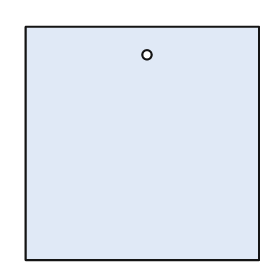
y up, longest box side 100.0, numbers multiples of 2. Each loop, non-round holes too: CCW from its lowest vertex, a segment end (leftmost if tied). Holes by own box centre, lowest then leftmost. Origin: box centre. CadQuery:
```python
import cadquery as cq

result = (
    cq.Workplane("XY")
    .moveTo(-50.0, -50.0)
    .lineTo(50.0, -50.0)
    .lineTo(50.0, 50.0)
    .lineTo(-50.0, 50.0)
    .close()
    .moveTo(2.0, 38.0)
    .circle(2.0)
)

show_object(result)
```